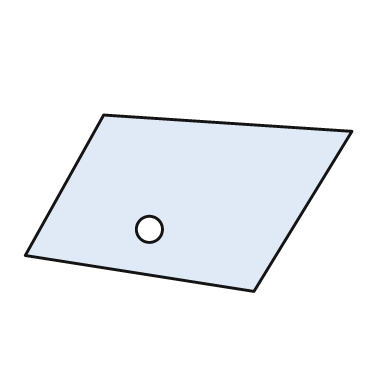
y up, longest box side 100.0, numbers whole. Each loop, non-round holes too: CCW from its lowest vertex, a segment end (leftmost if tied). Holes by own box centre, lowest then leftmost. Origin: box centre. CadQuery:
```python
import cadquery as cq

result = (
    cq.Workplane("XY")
    .moveTo(20.0, -27.0)
    .lineTo(50.0, 22.0)
    .lineTo(-26.0, 27.0)
    .lineTo(-50.0, -16.0)
    .close()
    .moveTo(-12.0, -8.0)
    .circle(4.0)
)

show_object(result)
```